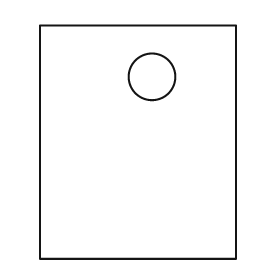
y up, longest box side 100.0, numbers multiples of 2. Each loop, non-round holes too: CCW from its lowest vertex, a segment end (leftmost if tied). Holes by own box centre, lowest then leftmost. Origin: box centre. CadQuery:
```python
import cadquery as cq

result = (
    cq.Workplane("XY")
    .moveTo(-42.0, -50.0)
    .lineTo(42.0, -50.0)
    .lineTo(42.0, 50.0)
    .lineTo(-42.0, 50.0)
    .close()
    .moveTo(6.0, 28.0)
    .circle(10.0)
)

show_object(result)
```